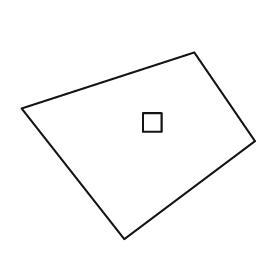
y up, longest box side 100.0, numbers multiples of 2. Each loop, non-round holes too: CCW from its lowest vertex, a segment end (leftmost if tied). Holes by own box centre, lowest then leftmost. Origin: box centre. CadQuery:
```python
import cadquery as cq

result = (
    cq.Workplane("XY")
    .moveTo(-6.0, -40.0)
    .lineTo(50.0, 2.0)
    .lineTo(24.0, 40.0)
    .lineTo(-50.0, 16.0)
    .close()
    .moveTo(2.0, 6.0)
    .lineTo(10.0, 6.0)
    .lineTo(10.0, 14.0)
    .lineTo(2.0, 14.0)
    .close()
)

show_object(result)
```